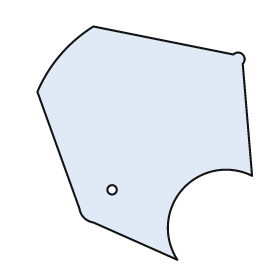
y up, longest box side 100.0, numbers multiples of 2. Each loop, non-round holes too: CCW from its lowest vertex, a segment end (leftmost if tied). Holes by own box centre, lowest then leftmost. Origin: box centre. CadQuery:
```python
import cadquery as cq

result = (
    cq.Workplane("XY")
    .moveTo(14.0, -50.0)
    .threePointArc((16.0, -20.0), (46.0, -14.0))
    .lineTo(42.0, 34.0)
    .threePointArc((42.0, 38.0), (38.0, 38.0))
    .lineTo(-22.0, 50.0)
    .threePointArc((-36.0, 38.0), (-46.0, 22.0))
    .lineTo(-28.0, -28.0)
    .threePointArc((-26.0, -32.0), (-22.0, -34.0))
    .close()
    .moveTo(-14.0, -20.0)
    .circle(2.0)
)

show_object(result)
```